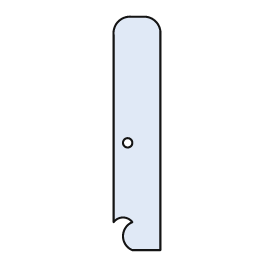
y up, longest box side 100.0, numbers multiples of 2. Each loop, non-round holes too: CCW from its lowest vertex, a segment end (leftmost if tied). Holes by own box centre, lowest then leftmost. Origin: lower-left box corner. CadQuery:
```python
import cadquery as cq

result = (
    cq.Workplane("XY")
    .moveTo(8.0, 0.0)
    .lineTo(20.0, 0.0)
    .lineTo(20.0, 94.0)
    .threePointArc((18.0, 98.0), (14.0, 100.0))
    .lineTo(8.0, 100.0)
    .threePointArc((2.0, 98.0), (0.0, 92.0))
    .lineTo(0.0, 12.0)
    .threePointArc((4.0, 14.0), (8.0, 12.0))
    .threePointArc((4.0, 6.0), (8.0, 0.0))
    .close()
    .moveTo(6.0, 46.0)
    .circle(2.0)
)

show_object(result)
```